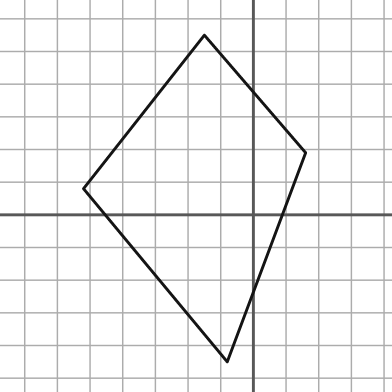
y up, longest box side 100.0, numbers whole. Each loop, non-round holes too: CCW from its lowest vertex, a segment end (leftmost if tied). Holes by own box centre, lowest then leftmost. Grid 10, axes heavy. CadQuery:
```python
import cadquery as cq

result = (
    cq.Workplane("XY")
    .moveTo(-8.0, -45.0)
    .lineTo(16.0, 19.0)
    .lineTo(-15.0, 55.0)
    .lineTo(-52.0, 8.0)
    .close()
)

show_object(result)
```